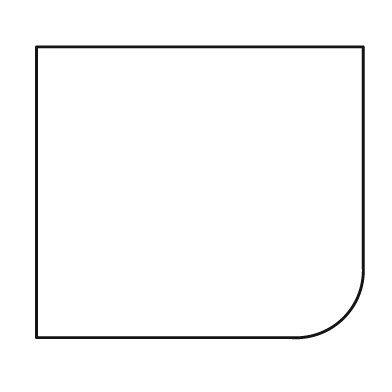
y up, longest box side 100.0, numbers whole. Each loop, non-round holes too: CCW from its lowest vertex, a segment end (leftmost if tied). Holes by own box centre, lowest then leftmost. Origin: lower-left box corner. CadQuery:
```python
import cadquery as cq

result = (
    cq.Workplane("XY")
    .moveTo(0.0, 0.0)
    .lineTo(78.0, 0.0)
    .threePointArc((94.0, 6.0), (100.0, 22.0))
    .lineTo(100.0, 89.0)
    .lineTo(0.0, 89.0)
    .close()
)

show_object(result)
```